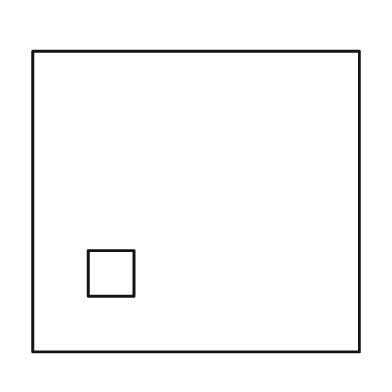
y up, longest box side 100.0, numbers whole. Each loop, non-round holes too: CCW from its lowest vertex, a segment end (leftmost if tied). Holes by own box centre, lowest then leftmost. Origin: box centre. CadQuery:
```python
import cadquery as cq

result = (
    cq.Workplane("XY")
    .moveTo(-50.0, -46.0)
    .lineTo(50.0, -46.0)
    .lineTo(50.0, 46.0)
    .lineTo(-50.0, 46.0)
    .close()
    .moveTo(-33.0, -29.0)
    .lineTo(-19.0, -29.0)
    .lineTo(-19.0, -15.0)
    .lineTo(-33.0, -15.0)
    .close()
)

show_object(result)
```